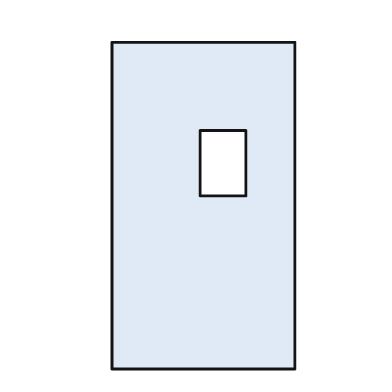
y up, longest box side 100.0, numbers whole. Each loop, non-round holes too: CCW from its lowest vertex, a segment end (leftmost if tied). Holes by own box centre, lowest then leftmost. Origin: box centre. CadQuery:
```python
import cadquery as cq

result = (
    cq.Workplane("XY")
    .moveTo(-28.0, -50.0)
    .lineTo(28.0, -50.0)
    .lineTo(28.0, 50.0)
    .lineTo(-28.0, 50.0)
    .close()
    .moveTo(-1.0, 3.0)
    .lineTo(13.0, 3.0)
    .lineTo(13.0, 23.0)
    .lineTo(-1.0, 23.0)
    .close()
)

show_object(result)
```